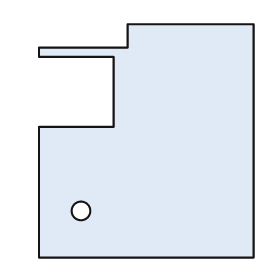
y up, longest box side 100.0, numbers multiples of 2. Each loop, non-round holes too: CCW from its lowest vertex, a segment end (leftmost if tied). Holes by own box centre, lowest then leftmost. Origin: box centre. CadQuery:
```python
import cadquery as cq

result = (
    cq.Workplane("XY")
    .moveTo(-46.0, -50.0)
    .lineTo(46.0, -50.0)
    .lineTo(46.0, 50.0)
    .lineTo(-8.0, 50.0)
    .lineTo(-8.0, 40.0)
    .lineTo(-46.0, 40.0)
    .lineTo(-46.0, 36.0)
    .lineTo(-14.0, 36.0)
    .lineTo(-14.0, 6.0)
    .lineTo(-46.0, 6.0)
    .close()
    .moveTo(-28.0, -30.0)
    .circle(4.0)
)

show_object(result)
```